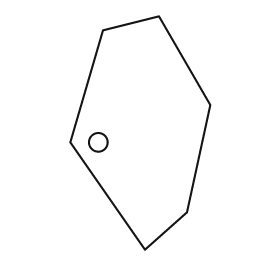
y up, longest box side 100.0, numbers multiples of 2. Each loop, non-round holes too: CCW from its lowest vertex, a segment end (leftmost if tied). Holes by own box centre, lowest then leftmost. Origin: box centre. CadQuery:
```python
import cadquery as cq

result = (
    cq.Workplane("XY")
    .moveTo(2.0, -50.0)
    .lineTo(20.0, -34.0)
    .lineTo(30.0, 12.0)
    .lineTo(8.0, 50.0)
    .lineTo(-16.0, 44.0)
    .lineTo(-30.0, -4.0)
    .close()
    .moveTo(-18.0, -4.0)
    .circle(4.0)
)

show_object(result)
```